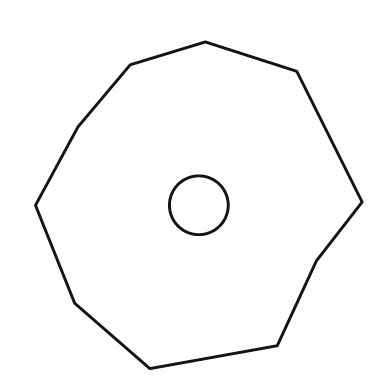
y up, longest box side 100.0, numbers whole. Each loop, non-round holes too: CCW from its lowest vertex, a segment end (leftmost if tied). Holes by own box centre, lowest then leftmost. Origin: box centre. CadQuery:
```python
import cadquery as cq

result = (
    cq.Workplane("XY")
    .moveTo(-15.0, -50.0)
    .lineTo(24.0, -43.0)
    .lineTo(36.0, -17.0)
    .lineTo(50.0, 1.0)
    .lineTo(30.0, 41.0)
    .lineTo(2.0, 50.0)
    .lineTo(-21.0, 43.0)
    .lineTo(-37.0, 24.0)
    .lineTo(-50.0, 0.0)
    .lineTo(-38.0, -30.0)
    .close()
    .moveTo(0.0, 0.0)
    .circle(9.0)
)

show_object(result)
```